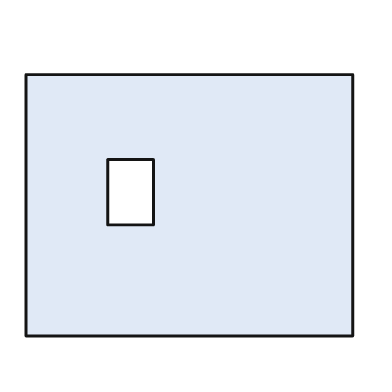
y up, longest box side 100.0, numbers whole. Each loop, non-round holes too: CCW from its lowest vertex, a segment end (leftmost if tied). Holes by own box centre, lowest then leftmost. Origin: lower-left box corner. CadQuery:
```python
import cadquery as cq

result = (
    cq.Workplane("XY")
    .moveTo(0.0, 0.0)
    .lineTo(100.0, 0.0)
    .lineTo(100.0, 80.0)
    .lineTo(0.0, 80.0)
    .close()
    .moveTo(25.0, 34.0)
    .lineTo(39.0, 34.0)
    .lineTo(39.0, 54.0)
    .lineTo(25.0, 54.0)
    .close()
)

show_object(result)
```